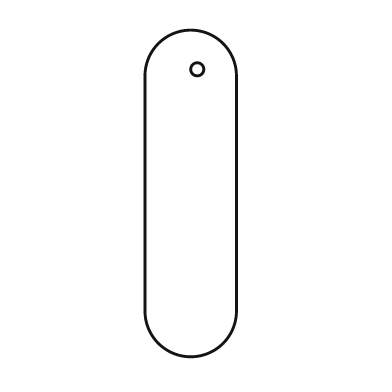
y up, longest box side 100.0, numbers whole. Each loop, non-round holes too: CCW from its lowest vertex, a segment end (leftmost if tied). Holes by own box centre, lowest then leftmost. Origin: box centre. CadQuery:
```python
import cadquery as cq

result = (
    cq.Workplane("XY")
    .moveTo(-14.0, -36.0)
    .threePointArc((0.0, -50.0), (14.0, -36.0))
    .lineTo(14.0, 36.0)
    .threePointArc((0.0, 50.0), (-14.0, 36.0))
    .close()
    .moveTo(2.0, 38.0)
    .circle(2.0)
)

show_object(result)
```